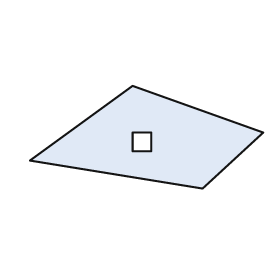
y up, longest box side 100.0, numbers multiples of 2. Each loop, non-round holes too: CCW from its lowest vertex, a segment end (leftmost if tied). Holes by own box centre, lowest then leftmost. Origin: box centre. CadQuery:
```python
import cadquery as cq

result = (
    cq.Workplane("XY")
    .moveTo(24.0, -22.0)
    .lineTo(50.0, 2.0)
    .lineTo(-6.0, 22.0)
    .lineTo(-50.0, -10.0)
    .close()
    .moveTo(-6.0, -6.0)
    .lineTo(2.0, -6.0)
    .lineTo(2.0, 2.0)
    .lineTo(-6.0, 2.0)
    .close()
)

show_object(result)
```